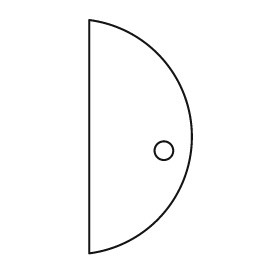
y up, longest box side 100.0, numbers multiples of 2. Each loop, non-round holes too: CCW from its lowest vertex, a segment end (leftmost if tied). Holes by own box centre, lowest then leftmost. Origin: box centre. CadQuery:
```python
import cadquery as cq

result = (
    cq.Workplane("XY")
    .moveTo(-22.0, -50.0)
    .threePointArc((22.0, 0.0), (-22.0, 50.0))
    .close()
    .moveTo(10.0, -6.0)
    .circle(4.0)
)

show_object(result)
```